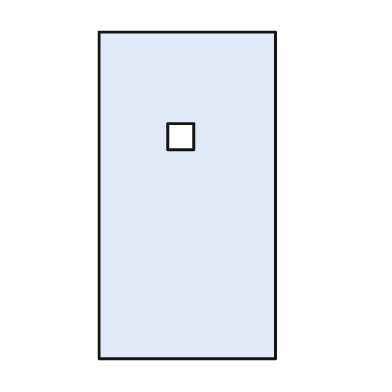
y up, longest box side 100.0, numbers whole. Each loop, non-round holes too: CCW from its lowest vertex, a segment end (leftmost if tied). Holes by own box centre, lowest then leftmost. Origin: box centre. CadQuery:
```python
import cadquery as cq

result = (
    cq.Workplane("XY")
    .moveTo(-27.0, -50.0)
    .lineTo(27.0, -50.0)
    .lineTo(27.0, 50.0)
    .lineTo(-27.0, 50.0)
    .close()
    .moveTo(-6.0, 14.0)
    .lineTo(2.0, 14.0)
    .lineTo(2.0, 22.0)
    .lineTo(-6.0, 22.0)
    .close()
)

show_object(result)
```